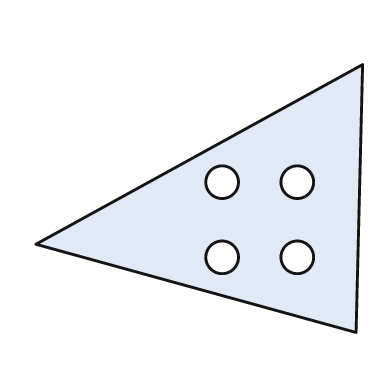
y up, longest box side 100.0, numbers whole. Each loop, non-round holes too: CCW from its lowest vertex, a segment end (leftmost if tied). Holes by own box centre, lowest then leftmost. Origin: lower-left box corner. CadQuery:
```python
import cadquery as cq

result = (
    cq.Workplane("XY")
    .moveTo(98.0, 0.0)
    .lineTo(100.0, 82.0)
    .lineTo(0.0, 27.0)
    .close()
    .moveTo(57.0, 23.0)
    .circle(5.0)
    .moveTo(80.0, 23.0)
    .circle(5.0)
    .moveTo(57.0, 46.0)
    .circle(5.0)
    .moveTo(80.0, 46.0)
    .circle(5.0)
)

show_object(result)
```